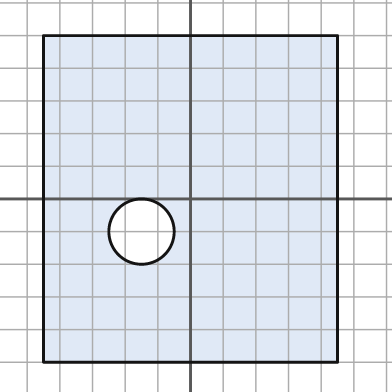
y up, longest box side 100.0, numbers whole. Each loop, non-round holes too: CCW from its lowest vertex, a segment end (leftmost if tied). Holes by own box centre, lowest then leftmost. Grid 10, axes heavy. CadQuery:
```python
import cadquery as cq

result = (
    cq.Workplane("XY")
    .moveTo(-45.0, -50.0)
    .lineTo(45.0, -50.0)
    .lineTo(45.0, 50.0)
    .lineTo(-45.0, 50.0)
    .close()
    .moveTo(-15.0, -10.0)
    .circle(10.0)
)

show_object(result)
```